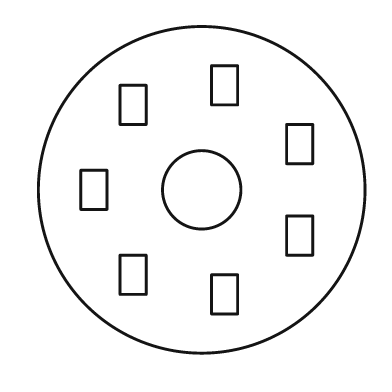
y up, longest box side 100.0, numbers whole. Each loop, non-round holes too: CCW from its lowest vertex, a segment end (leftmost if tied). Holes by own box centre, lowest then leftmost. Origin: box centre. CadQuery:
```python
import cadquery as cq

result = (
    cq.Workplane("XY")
    .moveTo(0.0, 0.0)
    .circle(50.0)
    .moveTo(3.0, -38.0)
    .lineTo(11.0, -38.0)
    .lineTo(11.0, -26.0)
    .lineTo(3.0, -26.0)
    .close()
    .moveTo(-25.0, -32.0)
    .lineTo(-17.0, -32.0)
    .lineTo(-17.0, -20.0)
    .lineTo(-25.0, -20.0)
    .close()
    .moveTo(26.0, -20.0)
    .lineTo(34.0, -20.0)
    .lineTo(34.0, -8.0)
    .lineTo(26.0, -8.0)
    .close()
    .moveTo(-37.0, -6.0)
    .lineTo(-29.0, -6.0)
    .lineTo(-29.0, 6.0)
    .lineTo(-37.0, 6.0)
    .close()
    .moveTo(0.0, 0.0)
    .circle(12.0)
    .moveTo(26.0, 8.0)
    .lineTo(34.0, 8.0)
    .lineTo(34.0, 20.0)
    .lineTo(26.0, 20.0)
    .close()
    .moveTo(-25.0, 20.0)
    .lineTo(-17.0, 20.0)
    .lineTo(-17.0, 32.0)
    .lineTo(-25.0, 32.0)
    .close()
    .moveTo(3.0, 26.0)
    .lineTo(11.0, 26.0)
    .lineTo(11.0, 38.0)
    .lineTo(3.0, 38.0)
    .close()
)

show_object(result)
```